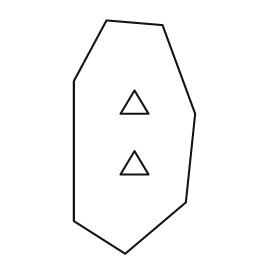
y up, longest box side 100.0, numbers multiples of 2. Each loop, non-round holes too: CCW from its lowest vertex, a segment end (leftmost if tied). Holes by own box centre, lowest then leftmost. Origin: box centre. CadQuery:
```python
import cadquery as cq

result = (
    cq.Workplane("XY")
    .moveTo(-4.0, -50.0)
    .lineTo(22.0, -28.0)
    .lineTo(26.0, 10.0)
    .lineTo(12.0, 48.0)
    .lineTo(-12.0, 50.0)
    .lineTo(-26.0, 24.0)
    .lineTo(-26.0, -36.0)
    .close()
    .moveTo(-6.0, -16.0)
    .lineTo(6.0, -16.0)
    .lineTo(0.0, -6.0)
    .close()
    .moveTo(-6.0, 10.0)
    .lineTo(6.0, 10.0)
    .lineTo(0.0, 20.0)
    .close()
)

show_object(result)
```